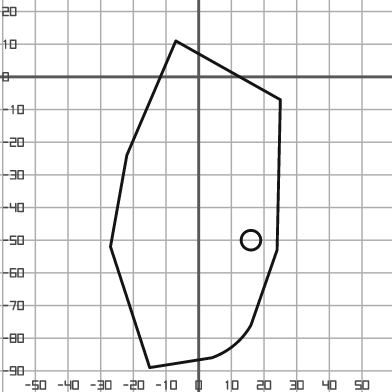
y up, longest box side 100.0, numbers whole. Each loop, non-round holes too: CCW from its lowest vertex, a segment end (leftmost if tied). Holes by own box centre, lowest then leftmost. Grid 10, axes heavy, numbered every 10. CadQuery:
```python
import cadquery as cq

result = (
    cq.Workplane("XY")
    .moveTo(-15.0, -89.0)
    .lineTo(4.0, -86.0)
    .threePointArc((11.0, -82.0), (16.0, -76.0))
    .lineTo(24.0, -53.0)
    .lineTo(25.0, -7.0)
    .lineTo(-7.0, 11.0)
    .lineTo(-22.0, -24.0)
    .lineTo(-27.0, -52.0)
    .close()
    .moveTo(16.0, -50.0)
    .circle(3.0)
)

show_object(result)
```